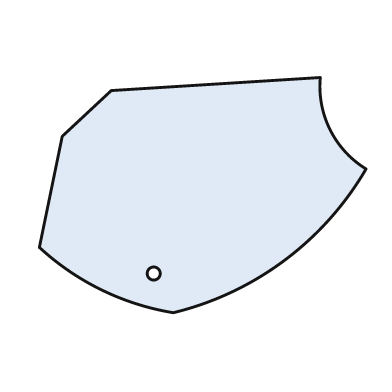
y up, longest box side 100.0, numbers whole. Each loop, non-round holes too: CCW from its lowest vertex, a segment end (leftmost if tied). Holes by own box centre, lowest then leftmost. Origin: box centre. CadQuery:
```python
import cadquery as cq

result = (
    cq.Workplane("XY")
    .moveTo(-9.0, -36.0)
    .threePointArc((25.0, -20.0), (50.0, 8.0))
    .threePointArc((39.0, 20.0), (36.0, 36.0))
    .lineTo(-28.0, 32.0)
    .lineTo(-43.0, 18.0)
    .lineTo(-50.0, -16.0)
    .threePointArc((-31.0, -29.0), (-9.0, -36.0))
    .close()
    .moveTo(-15.0, -24.0)
    .circle(2.0)
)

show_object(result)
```